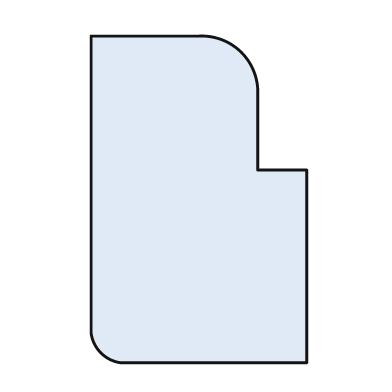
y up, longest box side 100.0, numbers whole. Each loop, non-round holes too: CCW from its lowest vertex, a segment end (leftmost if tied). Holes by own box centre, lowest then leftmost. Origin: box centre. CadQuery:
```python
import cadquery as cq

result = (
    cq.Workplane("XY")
    .moveTo(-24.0, -50.0)
    .lineTo(33.0, -50.0)
    .lineTo(33.0, 9.0)
    .lineTo(18.0, 9.0)
    .lineTo(18.0, 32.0)
    .threePointArc((13.0, 45.0), (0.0, 50.0))
    .lineTo(-33.0, 50.0)
    .lineTo(-33.0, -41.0)
    .threePointArc((-30.0, -47.0), (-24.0, -50.0))
    .close()
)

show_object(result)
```